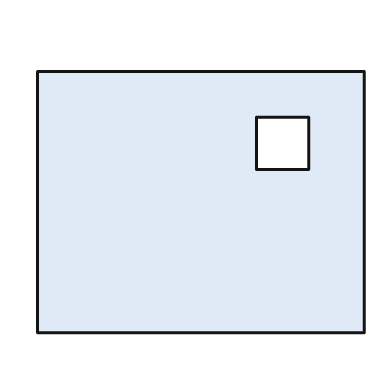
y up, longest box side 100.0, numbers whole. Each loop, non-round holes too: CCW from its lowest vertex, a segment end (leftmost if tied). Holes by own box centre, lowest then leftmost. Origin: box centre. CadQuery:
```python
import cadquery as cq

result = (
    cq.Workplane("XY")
    .moveTo(-50.0, -40.0)
    .lineTo(50.0, -40.0)
    .lineTo(50.0, 40.0)
    .lineTo(-50.0, 40.0)
    .close()
    .moveTo(17.0, 10.0)
    .lineTo(33.0, 10.0)
    .lineTo(33.0, 26.0)
    .lineTo(17.0, 26.0)
    .close()
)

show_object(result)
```